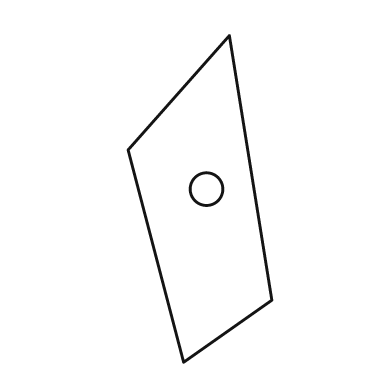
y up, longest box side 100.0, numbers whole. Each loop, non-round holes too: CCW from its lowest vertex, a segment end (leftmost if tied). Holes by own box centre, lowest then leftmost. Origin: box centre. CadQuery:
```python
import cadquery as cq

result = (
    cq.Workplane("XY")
    .moveTo(-5.0, -50.0)
    .lineTo(22.0, -31.0)
    .lineTo(9.0, 50.0)
    .lineTo(-22.0, 15.0)
    .close()
    .moveTo(2.0, 3.0)
    .circle(5.0)
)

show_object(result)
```